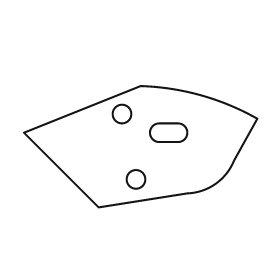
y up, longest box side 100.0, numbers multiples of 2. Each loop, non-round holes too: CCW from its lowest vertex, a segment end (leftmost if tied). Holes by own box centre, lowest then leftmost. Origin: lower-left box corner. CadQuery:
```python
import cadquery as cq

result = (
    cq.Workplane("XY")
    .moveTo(32.0, 0.0)
    .lineTo(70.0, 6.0)
    .threePointArc((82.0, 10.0), (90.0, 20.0))
    .lineTo(100.0, 38.0)
    .threePointArc((76.0, 48.0), (50.0, 52.0))
    .lineTo(0.0, 32.0)
    .close()
    .moveTo(48.0, 12.0)
    .circle(4.0)
    .moveTo(58.0, 28.0)
    .lineTo(66.0, 28.0)
    .threePointArc((70.0, 32.0), (66.0, 36.0))
    .lineTo(58.0, 36.0)
    .threePointArc((54.0, 32.0), (58.0, 28.0))
    .close()
    .moveTo(42.0, 40.0)
    .circle(4.0)
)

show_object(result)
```